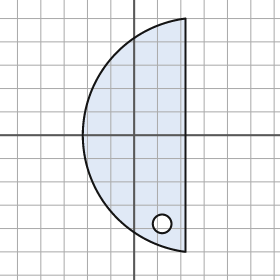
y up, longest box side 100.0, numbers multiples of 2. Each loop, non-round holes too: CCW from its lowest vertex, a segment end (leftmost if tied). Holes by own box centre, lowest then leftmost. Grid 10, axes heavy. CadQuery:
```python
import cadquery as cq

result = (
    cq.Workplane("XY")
    .moveTo(22.0, -50.0)
    .lineTo(22.0, 50.0)
    .threePointArc((-22.0, 0.0), (22.0, -50.0))
    .close()
    .moveTo(12.0, -38.0)
    .circle(4.0)
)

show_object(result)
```